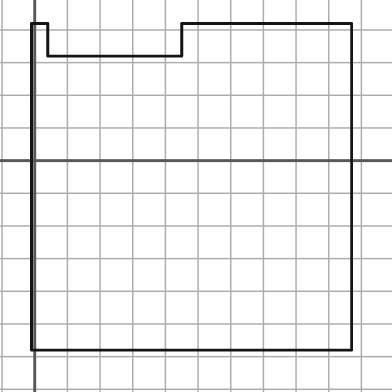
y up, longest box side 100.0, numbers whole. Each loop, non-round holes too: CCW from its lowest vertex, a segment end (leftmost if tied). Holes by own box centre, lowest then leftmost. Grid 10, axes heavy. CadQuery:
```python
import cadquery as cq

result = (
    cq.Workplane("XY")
    .moveTo(-1.0, -58.0)
    .lineTo(97.0, -58.0)
    .lineTo(97.0, 42.0)
    .lineTo(45.0, 42.0)
    .lineTo(45.0, 32.0)
    .lineTo(4.0, 32.0)
    .lineTo(4.0, 42.0)
    .lineTo(-1.0, 42.0)
    .close()
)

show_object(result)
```